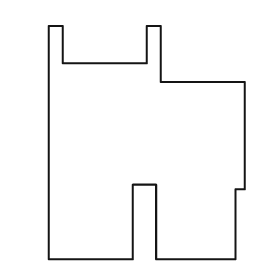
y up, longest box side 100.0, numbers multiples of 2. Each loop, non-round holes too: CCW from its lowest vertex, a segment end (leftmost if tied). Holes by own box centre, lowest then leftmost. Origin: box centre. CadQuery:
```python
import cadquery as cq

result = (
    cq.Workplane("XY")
    .moveTo(-42.0, -50.0)
    .lineTo(-6.0, -50.0)
    .lineTo(-6.0, -18.0)
    .lineTo(4.0, -18.0)
    .lineTo(4.0, -50.0)
    .lineTo(38.0, -50.0)
    .lineTo(38.0, -20.0)
    .lineTo(42.0, -20.0)
    .lineTo(42.0, 26.0)
    .lineTo(6.0, 26.0)
    .lineTo(6.0, 50.0)
    .lineTo(0.0, 50.0)
    .lineTo(0.0, 34.0)
    .lineTo(-36.0, 34.0)
    .lineTo(-36.0, 50.0)
    .lineTo(-42.0, 50.0)
    .close()
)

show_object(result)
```